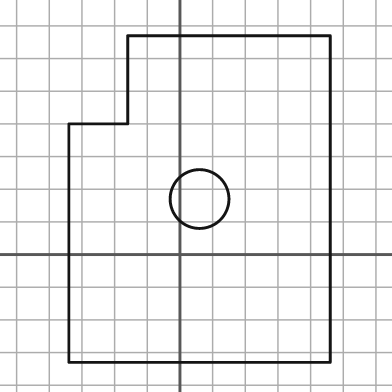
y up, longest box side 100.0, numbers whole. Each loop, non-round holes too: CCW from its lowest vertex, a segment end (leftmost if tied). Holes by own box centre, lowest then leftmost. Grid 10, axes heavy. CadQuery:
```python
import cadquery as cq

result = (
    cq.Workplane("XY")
    .moveTo(-34.0, -33.0)
    .lineTo(46.0, -33.0)
    .lineTo(46.0, 67.0)
    .lineTo(-16.0, 67.0)
    .lineTo(-16.0, 40.0)
    .lineTo(-34.0, 40.0)
    .close()
    .moveTo(6.0, 17.0)
    .circle(9.0)
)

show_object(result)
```